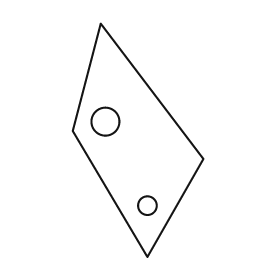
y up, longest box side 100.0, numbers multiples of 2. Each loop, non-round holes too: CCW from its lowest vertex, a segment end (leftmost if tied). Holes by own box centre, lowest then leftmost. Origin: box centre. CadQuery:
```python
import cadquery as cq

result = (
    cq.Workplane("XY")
    .moveTo(4.0, -50.0)
    .lineTo(28.0, -8.0)
    .lineTo(-16.0, 50.0)
    .lineTo(-28.0, 4.0)
    .close()
    .moveTo(4.0, -28.0)
    .circle(4.0)
    .moveTo(-14.0, 8.0)
    .circle(6.0)
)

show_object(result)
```